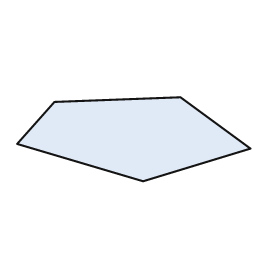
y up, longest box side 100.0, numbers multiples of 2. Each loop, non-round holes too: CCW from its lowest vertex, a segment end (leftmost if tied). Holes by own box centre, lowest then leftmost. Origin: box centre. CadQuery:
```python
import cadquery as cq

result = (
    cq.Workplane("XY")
    .moveTo(4.0, -18.0)
    .lineTo(50.0, -4.0)
    .lineTo(20.0, 18.0)
    .lineTo(-34.0, 16.0)
    .lineTo(-50.0, -2.0)
    .close()
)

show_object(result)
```